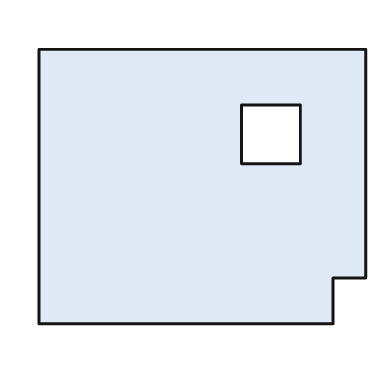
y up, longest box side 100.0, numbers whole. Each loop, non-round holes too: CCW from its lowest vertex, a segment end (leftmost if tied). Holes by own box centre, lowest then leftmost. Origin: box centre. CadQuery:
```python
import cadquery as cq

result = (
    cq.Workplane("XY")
    .moveTo(-50.0, -42.0)
    .lineTo(40.0, -42.0)
    .lineTo(40.0, -28.0)
    .lineTo(50.0, -28.0)
    .lineTo(50.0, 42.0)
    .lineTo(-50.0, 42.0)
    .close()
    .moveTo(12.0, 7.0)
    .lineTo(30.0, 7.0)
    .lineTo(30.0, 25.0)
    .lineTo(12.0, 25.0)
    .close()
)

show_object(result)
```